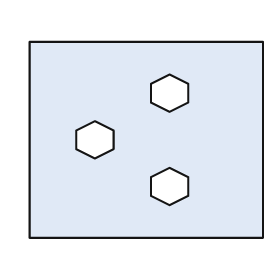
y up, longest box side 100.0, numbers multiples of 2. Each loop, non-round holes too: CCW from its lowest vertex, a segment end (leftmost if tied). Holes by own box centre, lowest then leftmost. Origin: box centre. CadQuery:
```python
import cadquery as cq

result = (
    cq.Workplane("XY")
    .moveTo(-50.0, -42.0)
    .lineTo(50.0, -42.0)
    .lineTo(50.0, 42.0)
    .lineTo(-50.0, 42.0)
    .close()
    .moveTo(10.0, -28.0)
    .lineTo(18.0, -24.0)
    .lineTo(18.0, -16.0)
    .lineTo(10.0, -12.0)
    .lineTo(2.0, -16.0)
    .lineTo(2.0, -24.0)
    .close()
    .moveTo(-22.0, -8.0)
    .lineTo(-14.0, -4.0)
    .lineTo(-14.0, 4.0)
    .lineTo(-22.0, 8.0)
    .lineTo(-30.0, 4.0)
    .lineTo(-30.0, -4.0)
    .close()
    .moveTo(10.0, 12.0)
    .lineTo(18.0, 16.0)
    .lineTo(18.0, 24.0)
    .lineTo(10.0, 28.0)
    .lineTo(2.0, 24.0)
    .lineTo(2.0, 16.0)
    .close()
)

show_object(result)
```